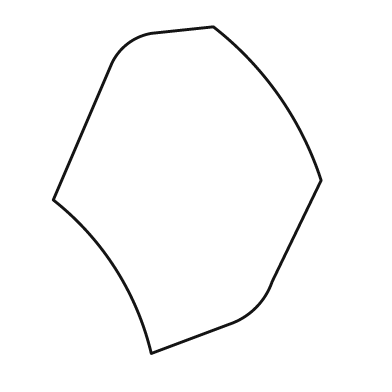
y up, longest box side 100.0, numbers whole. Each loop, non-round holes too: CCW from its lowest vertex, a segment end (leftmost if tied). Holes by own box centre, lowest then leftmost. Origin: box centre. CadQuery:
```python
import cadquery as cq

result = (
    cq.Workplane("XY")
    .moveTo(-11.0, -50.0)
    .lineTo(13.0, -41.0)
    .threePointArc((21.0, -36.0), (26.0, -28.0))
    .lineTo(41.0, 3.0)
    .threePointArc((28.0, 29.0), (8.0, 50.0))
    .lineTo(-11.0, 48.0)
    .threePointArc((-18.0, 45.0), (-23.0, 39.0))
    .lineTo(-41.0, -3.0)
    .threePointArc((-22.0, -24.0), (-11.0, -50.0))
    .close()
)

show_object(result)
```